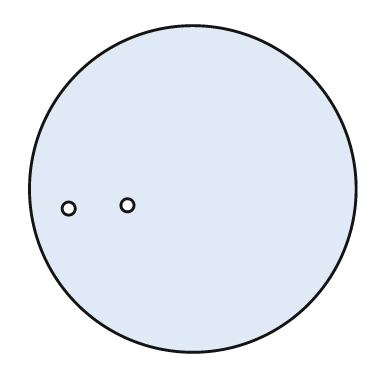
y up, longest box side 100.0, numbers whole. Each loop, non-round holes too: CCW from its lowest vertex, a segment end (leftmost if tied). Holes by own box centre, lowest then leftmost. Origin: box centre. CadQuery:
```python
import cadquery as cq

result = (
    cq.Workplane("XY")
    .moveTo(0.0, 0.0)
    .circle(50.0)
    .moveTo(-38.0, -6.0)
    .circle(2.0)
    .moveTo(-20.0, -5.0)
    .circle(2.0)
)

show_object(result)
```